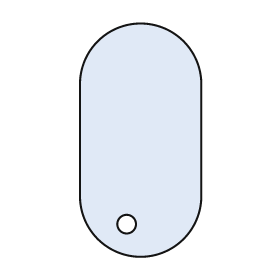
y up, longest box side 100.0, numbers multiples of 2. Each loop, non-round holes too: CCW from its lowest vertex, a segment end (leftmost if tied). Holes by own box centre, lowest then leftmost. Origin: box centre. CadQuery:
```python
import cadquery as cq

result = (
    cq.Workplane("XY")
    .moveTo(-26.0, -24.0)
    .threePointArc((0.0, -50.0), (26.0, -24.0))
    .lineTo(26.0, 24.0)
    .threePointArc((0.0, 50.0), (-26.0, 24.0))
    .close()
    .moveTo(-6.0, -36.0)
    .circle(4.0)
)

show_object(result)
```